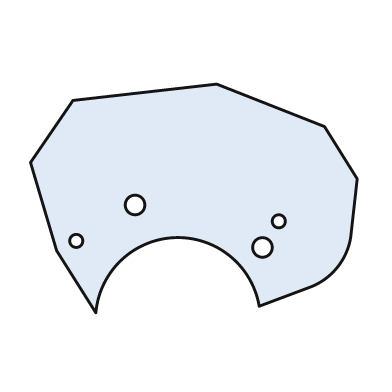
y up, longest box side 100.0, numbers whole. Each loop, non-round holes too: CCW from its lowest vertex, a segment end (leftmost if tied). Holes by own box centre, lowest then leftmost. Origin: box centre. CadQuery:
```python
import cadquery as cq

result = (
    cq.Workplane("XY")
    .moveTo(-30.0, -35.0)
    .threePointArc((-6.0, -12.0), (20.0, -33.0))
    .lineTo(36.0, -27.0)
    .threePointArc((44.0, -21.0), (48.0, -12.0))
    .lineTo(50.0, 6.0)
    .lineTo(40.0, 22.0)
    .lineTo(7.0, 35.0)
    .lineTo(-37.0, 30.0)
    .lineTo(-50.0, 11.0)
    .lineTo(-42.0, -16.0)
    .close()
    .moveTo(21.0, -15.0)
    .circle(3.0)
    .moveTo(-36.0, -13.0)
    .circle(2.0)
    .moveTo(26.0, -7.0)
    .circle(2.0)
    .moveTo(-18.0, -2.0)
    .circle(3.0)
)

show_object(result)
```